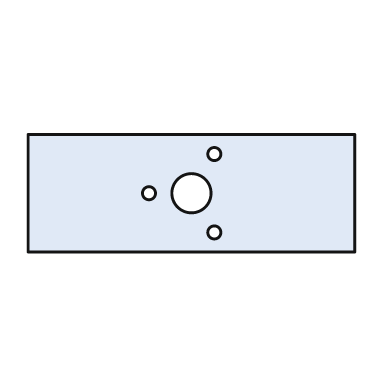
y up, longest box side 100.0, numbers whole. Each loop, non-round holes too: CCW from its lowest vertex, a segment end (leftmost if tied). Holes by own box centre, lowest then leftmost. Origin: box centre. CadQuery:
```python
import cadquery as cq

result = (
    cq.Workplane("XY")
    .moveTo(-50.0, -18.0)
    .lineTo(50.0, -18.0)
    .lineTo(50.0, 18.0)
    .lineTo(-50.0, 18.0)
    .close()
    .moveTo(7.0, -12.0)
    .circle(2.0)
    .moveTo(-13.0, 0.0)
    .circle(2.0)
    .moveTo(0.0, 0.0)
    .circle(6.0)
    .moveTo(7.0, 12.0)
    .circle(2.0)
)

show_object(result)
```